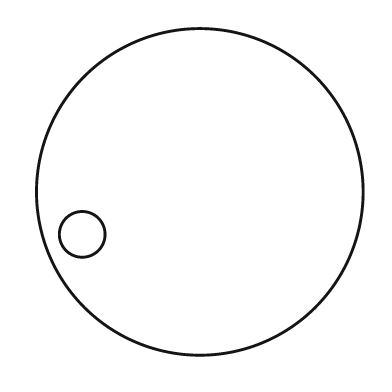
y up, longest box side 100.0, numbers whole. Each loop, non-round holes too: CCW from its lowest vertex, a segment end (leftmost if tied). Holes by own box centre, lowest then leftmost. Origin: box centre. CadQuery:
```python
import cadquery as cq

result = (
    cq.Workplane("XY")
    .moveTo(0.0, 0.0)
    .circle(50.0)
    .moveTo(-36.0, -13.0)
    .circle(7.0)
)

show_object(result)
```